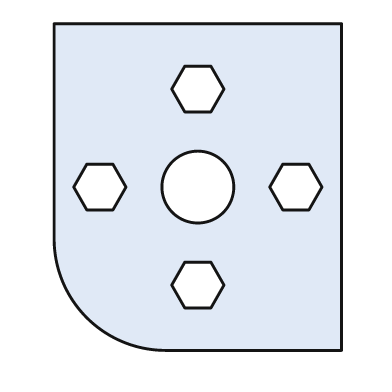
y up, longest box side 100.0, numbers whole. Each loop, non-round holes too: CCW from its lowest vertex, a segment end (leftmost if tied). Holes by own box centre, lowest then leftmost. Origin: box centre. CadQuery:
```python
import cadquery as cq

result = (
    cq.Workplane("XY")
    .moveTo(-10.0, -50.0)
    .lineTo(44.0, -50.0)
    .lineTo(44.0, 50.0)
    .lineTo(-44.0, 50.0)
    .lineTo(-44.0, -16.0)
    .threePointArc((-34.0, -40.0), (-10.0, -50.0))
    .close()
    .moveTo(-4.0, -37.0)
    .lineTo(4.0, -37.0)
    .lineTo(8.0, -30.0)
    .lineTo(4.0, -23.0)
    .lineTo(-4.0, -23.0)
    .lineTo(-8.0, -30.0)
    .close()
    .moveTo(-34.0, -7.0)
    .lineTo(-26.0, -7.0)
    .lineTo(-22.0, 0.0)
    .lineTo(-26.0, 7.0)
    .lineTo(-34.0, 7.0)
    .lineTo(-38.0, 0.0)
    .close()
    .moveTo(0.0, 0.0)
    .circle(11.0)
    .moveTo(26.0, -7.0)
    .lineTo(34.0, -7.0)
    .lineTo(38.0, 0.0)
    .lineTo(34.0, 7.0)
    .lineTo(26.0, 7.0)
    .lineTo(22.0, 0.0)
    .close()
    .moveTo(-4.0, 23.0)
    .lineTo(4.0, 23.0)
    .lineTo(8.0, 30.0)
    .lineTo(4.0, 37.0)
    .lineTo(-4.0, 37.0)
    .lineTo(-8.0, 30.0)
    .close()
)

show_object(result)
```